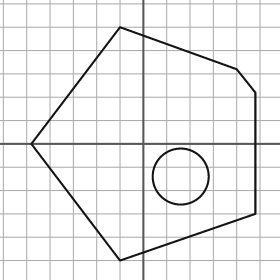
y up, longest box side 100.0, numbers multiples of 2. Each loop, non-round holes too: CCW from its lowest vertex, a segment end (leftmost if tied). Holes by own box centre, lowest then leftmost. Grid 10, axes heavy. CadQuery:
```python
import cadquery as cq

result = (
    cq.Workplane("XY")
    .moveTo(-10.0, -50.0)
    .lineTo(48.0, -30.0)
    .lineTo(48.0, 22.0)
    .lineTo(40.0, 32.0)
    .lineTo(-10.0, 50.0)
    .lineTo(-48.0, 0.0)
    .close()
    .moveTo(16.0, -14.0)
    .circle(12.0)
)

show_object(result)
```